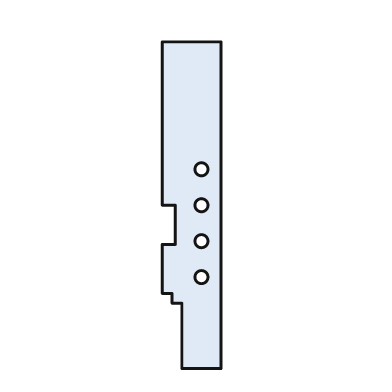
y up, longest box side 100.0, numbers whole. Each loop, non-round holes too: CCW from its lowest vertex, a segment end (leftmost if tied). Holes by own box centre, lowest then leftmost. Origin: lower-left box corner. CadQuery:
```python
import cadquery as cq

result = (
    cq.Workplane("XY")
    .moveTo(6.0, 0.0)
    .lineTo(18.0, 0.0)
    .lineTo(18.0, 100.0)
    .lineTo(0.0, 100.0)
    .lineTo(0.0, 50.0)
    .lineTo(4.0, 50.0)
    .lineTo(4.0, 38.0)
    .lineTo(0.0, 38.0)
    .lineTo(0.0, 23.0)
    .lineTo(3.0, 23.0)
    .lineTo(3.0, 20.0)
    .lineTo(6.0, 20.0)
    .close()
    .moveTo(12.0, 28.0)
    .circle(2.0)
    .moveTo(12.0, 39.0)
    .circle(2.0)
    .moveTo(12.0, 50.0)
    .circle(2.0)
    .moveTo(12.0, 61.0)
    .circle(2.0)
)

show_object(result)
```